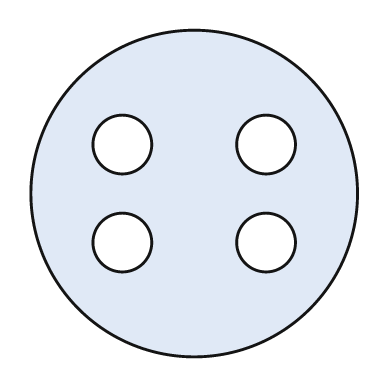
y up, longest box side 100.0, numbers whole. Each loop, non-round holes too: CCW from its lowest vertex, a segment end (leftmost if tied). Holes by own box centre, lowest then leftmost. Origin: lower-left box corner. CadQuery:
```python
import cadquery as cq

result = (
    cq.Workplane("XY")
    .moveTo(50.0, 50.0)
    .circle(50.0)
    .moveTo(28.0, 35.0)
    .circle(9.0)
    .moveTo(72.0, 35.0)
    .circle(9.0)
    .moveTo(28.0, 65.0)
    .circle(9.0)
    .moveTo(72.0, 65.0)
    .circle(9.0)
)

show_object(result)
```